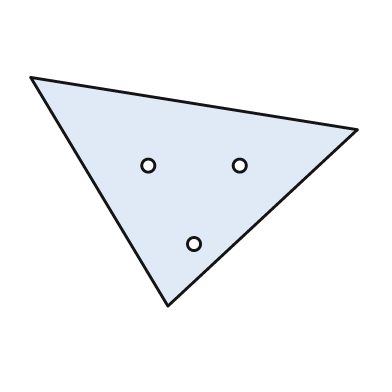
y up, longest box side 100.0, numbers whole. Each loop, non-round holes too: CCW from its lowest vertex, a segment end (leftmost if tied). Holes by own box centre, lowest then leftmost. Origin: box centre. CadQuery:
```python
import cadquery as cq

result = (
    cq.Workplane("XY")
    .moveTo(-8.0, -35.0)
    .lineTo(50.0, 19.0)
    .lineTo(-50.0, 35.0)
    .close()
    .moveTo(0.0, -16.0)
    .circle(2.0)
    .moveTo(-14.0, 8.0)
    .circle(2.0)
    .moveTo(14.0, 8.0)
    .circle(2.0)
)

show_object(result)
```